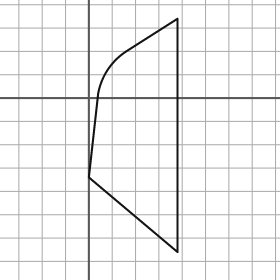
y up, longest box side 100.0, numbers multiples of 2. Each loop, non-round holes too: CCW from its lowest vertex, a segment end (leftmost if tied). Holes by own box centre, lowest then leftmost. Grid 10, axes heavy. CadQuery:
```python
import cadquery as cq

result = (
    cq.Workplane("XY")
    .moveTo(38.0, -66.0)
    .lineTo(38.0, 34.0)
    .lineTo(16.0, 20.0)
    .threePointArc((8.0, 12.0), (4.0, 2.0))
    .lineTo(0.0, -34.0)
    .close()
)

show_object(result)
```